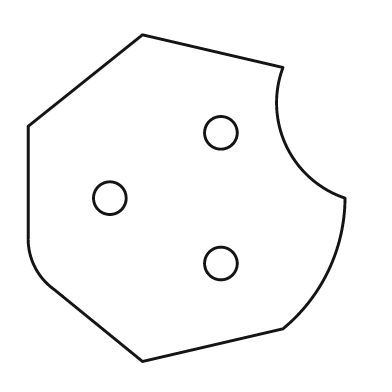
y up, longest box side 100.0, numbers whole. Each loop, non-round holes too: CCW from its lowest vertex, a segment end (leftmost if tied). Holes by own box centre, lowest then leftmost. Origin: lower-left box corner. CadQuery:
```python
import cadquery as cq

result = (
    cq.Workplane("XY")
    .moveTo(35.0, 0.0)
    .lineTo(78.0, 10.0)
    .threePointArc((92.0, 28.0), (97.0, 50.0))
    .threePointArc((79.0, 66.0), (78.0, 90.0))
    .lineTo(35.0, 100.0)
    .lineTo(0.0, 72.0)
    .lineTo(0.0, 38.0)
    .threePointArc((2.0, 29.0), (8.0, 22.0))
    .close()
    .moveTo(59.0, 30.0)
    .circle(5.0)
    .moveTo(25.0, 50.0)
    .circle(5.0)
    .moveTo(59.0, 70.0)
    .circle(5.0)
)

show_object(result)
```